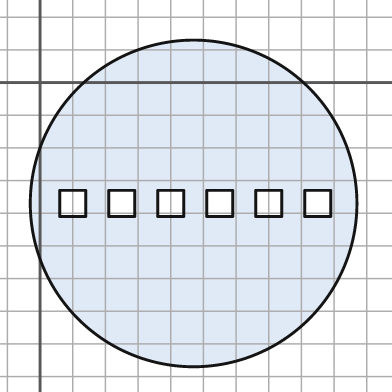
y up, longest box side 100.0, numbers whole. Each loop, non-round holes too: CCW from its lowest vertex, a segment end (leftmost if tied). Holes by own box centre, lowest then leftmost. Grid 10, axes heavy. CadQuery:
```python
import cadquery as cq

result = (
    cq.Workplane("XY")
    .moveTo(47.0, -37.0)
    .circle(50.0)
    .moveTo(6.0, -41.0)
    .lineTo(14.0, -41.0)
    .lineTo(14.0, -33.0)
    .lineTo(6.0, -33.0)
    .close()
    .moveTo(21.0, -41.0)
    .lineTo(29.0, -41.0)
    .lineTo(29.0, -33.0)
    .lineTo(21.0, -33.0)
    .close()
    .moveTo(36.0, -41.0)
    .lineTo(44.0, -41.0)
    .lineTo(44.0, -33.0)
    .lineTo(36.0, -33.0)
    .close()
    .moveTo(51.0, -41.0)
    .lineTo(59.0, -41.0)
    .lineTo(59.0, -33.0)
    .lineTo(51.0, -33.0)
    .close()
    .moveTo(66.0, -41.0)
    .lineTo(74.0, -41.0)
    .lineTo(74.0, -33.0)
    .lineTo(66.0, -33.0)
    .close()
    .moveTo(81.0, -41.0)
    .lineTo(89.0, -41.0)
    .lineTo(89.0, -33.0)
    .lineTo(81.0, -33.0)
    .close()
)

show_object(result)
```